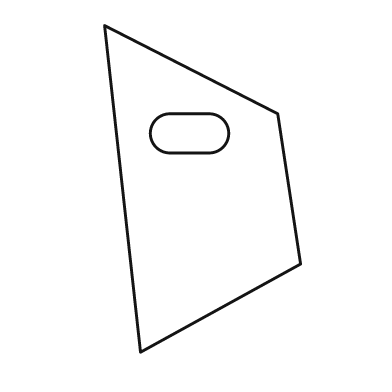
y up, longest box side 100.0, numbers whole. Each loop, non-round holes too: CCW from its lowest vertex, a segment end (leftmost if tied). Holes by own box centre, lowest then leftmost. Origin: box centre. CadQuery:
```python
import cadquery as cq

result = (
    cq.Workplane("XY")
    .moveTo(-19.0, -50.0)
    .lineTo(30.0, -23.0)
    .lineTo(23.0, 23.0)
    .lineTo(-30.0, 50.0)
    .close()
    .moveTo(-10.0, 11.0)
    .lineTo(2.0, 11.0)
    .threePointArc((8.0, 17.0), (2.0, 23.0))
    .lineTo(-10.0, 23.0)
    .threePointArc((-16.0, 17.0), (-10.0, 11.0))
    .close()
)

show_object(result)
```